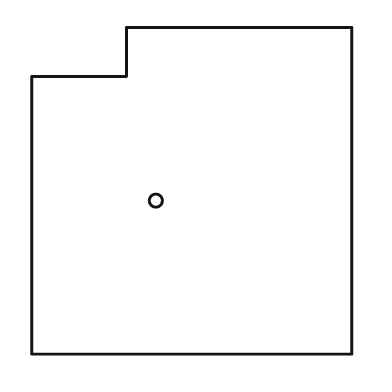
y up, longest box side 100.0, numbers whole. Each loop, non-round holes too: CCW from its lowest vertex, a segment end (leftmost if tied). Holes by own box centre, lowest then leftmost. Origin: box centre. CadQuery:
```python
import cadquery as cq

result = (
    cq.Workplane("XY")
    .moveTo(-49.0, -50.0)
    .lineTo(49.0, -50.0)
    .lineTo(49.0, 50.0)
    .lineTo(-20.0, 50.0)
    .lineTo(-20.0, 35.0)
    .lineTo(-49.0, 35.0)
    .close()
    .moveTo(-11.0, -3.0)
    .circle(2.0)
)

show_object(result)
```